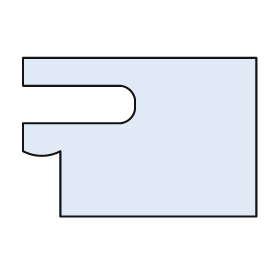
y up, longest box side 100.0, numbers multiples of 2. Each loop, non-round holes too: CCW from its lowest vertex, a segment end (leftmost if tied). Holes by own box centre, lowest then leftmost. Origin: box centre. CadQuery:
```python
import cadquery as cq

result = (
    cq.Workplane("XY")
    .moveTo(-34.0, -34.0)
    .lineTo(50.0, -34.0)
    .lineTo(50.0, 34.0)
    .lineTo(-50.0, 34.0)
    .lineTo(-50.0, 22.0)
    .lineTo(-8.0, 22.0)
    .threePointArc((-4.0, 20.0), (-2.0, 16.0))
    .lineTo(-2.0, 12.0)
    .threePointArc((-4.0, 8.0), (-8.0, 6.0))
    .lineTo(-50.0, 6.0)
    .lineTo(-50.0, -6.0)
    .threePointArc((-42.0, -8.0), (-34.0, -6.0))
    .close()
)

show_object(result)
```